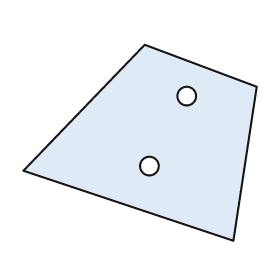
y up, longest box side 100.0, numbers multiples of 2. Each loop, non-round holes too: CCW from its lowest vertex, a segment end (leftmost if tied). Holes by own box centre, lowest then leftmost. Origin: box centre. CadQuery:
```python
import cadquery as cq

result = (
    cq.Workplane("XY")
    .moveTo(40.0, -42.0)
    .lineTo(50.0, 24.0)
    .lineTo(2.0, 42.0)
    .lineTo(-50.0, -12.0)
    .close()
    .moveTo(4.0, -10.0)
    .circle(4.0)
    .moveTo(20.0, 20.0)
    .circle(4.0)
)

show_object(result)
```